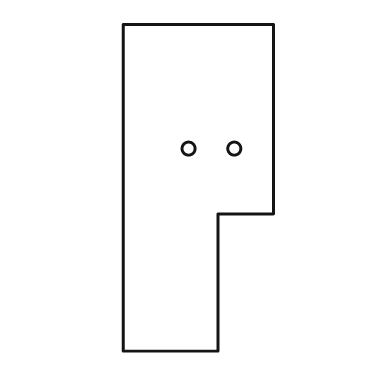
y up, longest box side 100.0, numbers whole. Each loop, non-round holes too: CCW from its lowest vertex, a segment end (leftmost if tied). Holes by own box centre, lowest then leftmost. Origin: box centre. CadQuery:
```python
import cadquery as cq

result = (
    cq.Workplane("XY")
    .moveTo(-23.0, -50.0)
    .lineTo(6.0, -50.0)
    .lineTo(6.0, -8.0)
    .lineTo(23.0, -8.0)
    .lineTo(23.0, 50.0)
    .lineTo(-23.0, 50.0)
    .close()
    .moveTo(-3.0, 12.0)
    .circle(2.0)
    .moveTo(11.0, 12.0)
    .circle(2.0)
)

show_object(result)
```